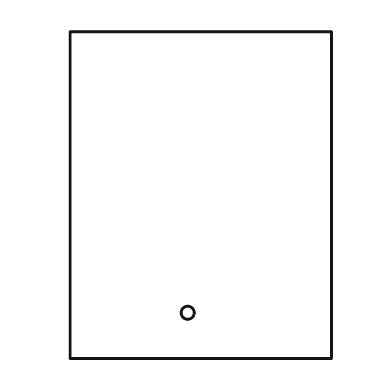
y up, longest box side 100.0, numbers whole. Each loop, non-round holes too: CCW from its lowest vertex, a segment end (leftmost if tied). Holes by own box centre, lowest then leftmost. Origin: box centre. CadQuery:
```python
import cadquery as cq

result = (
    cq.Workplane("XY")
    .moveTo(-40.0, -50.0)
    .lineTo(40.0, -50.0)
    .lineTo(40.0, 50.0)
    .lineTo(-40.0, 50.0)
    .close()
    .moveTo(-4.0, -36.0)
    .circle(2.0)
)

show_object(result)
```